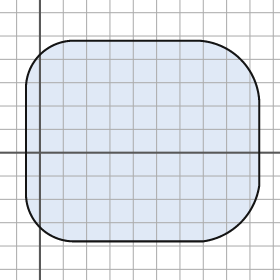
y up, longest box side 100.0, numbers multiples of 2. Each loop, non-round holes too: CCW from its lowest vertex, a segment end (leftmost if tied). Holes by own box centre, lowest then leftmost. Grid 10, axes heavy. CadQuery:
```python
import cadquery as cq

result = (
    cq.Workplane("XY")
    .moveTo(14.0, -38.0)
    .lineTo(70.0, -38.0)
    .threePointArc((86.0, -30.0), (94.0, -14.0))
    .lineTo(94.0, 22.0)
    .threePointArc((86.0, 40.0), (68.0, 48.0))
    .lineTo(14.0, 48.0)
    .threePointArc((0.0, 42.0), (-6.0, 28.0))
    .lineTo(-6.0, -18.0)
    .threePointArc((0.0, -32.0), (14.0, -38.0))
    .close()
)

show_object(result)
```